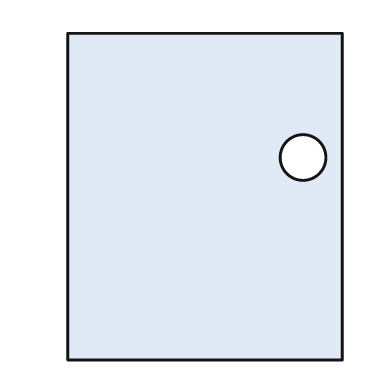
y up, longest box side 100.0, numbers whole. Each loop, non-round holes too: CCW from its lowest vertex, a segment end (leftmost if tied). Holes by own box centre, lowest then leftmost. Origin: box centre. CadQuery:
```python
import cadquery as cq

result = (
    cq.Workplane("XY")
    .moveTo(-42.0, -50.0)
    .lineTo(42.0, -50.0)
    .lineTo(42.0, 50.0)
    .lineTo(-42.0, 50.0)
    .close()
    .moveTo(30.0, 12.0)
    .circle(7.0)
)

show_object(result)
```